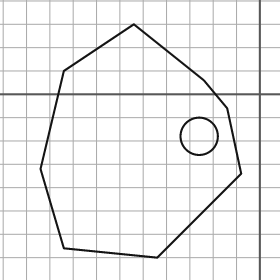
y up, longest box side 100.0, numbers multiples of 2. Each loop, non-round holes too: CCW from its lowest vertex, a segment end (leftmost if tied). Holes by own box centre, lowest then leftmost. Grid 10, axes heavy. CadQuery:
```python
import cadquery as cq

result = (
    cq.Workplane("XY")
    .moveTo(-44.0, -70.0)
    .lineTo(-8.0, -34.0)
    .lineTo(-14.0, -6.0)
    .lineTo(-24.0, 6.0)
    .lineTo(-54.0, 30.0)
    .lineTo(-84.0, 10.0)
    .lineTo(-94.0, -32.0)
    .lineTo(-84.0, -66.0)
    .close()
    .moveTo(-26.0, -18.0)
    .circle(8.0)
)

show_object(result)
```